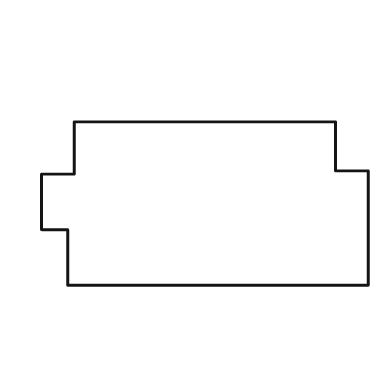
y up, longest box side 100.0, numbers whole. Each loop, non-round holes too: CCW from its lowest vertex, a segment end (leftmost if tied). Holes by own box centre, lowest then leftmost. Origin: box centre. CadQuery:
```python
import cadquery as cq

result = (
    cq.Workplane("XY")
    .moveTo(-42.0, -25.0)
    .lineTo(50.0, -25.0)
    .lineTo(50.0, 10.0)
    .lineTo(40.0, 10.0)
    .lineTo(40.0, 25.0)
    .lineTo(-40.0, 25.0)
    .lineTo(-40.0, 9.0)
    .lineTo(-50.0, 9.0)
    .lineTo(-50.0, -8.0)
    .lineTo(-42.0, -8.0)
    .close()
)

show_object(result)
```